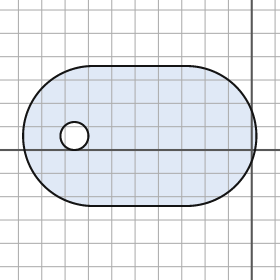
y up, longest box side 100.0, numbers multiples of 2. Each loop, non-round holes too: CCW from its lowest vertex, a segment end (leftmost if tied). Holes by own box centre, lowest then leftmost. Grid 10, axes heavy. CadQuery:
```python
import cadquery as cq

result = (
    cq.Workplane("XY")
    .moveTo(-68.0, -24.0)
    .lineTo(-28.0, -24.0)
    .threePointArc((2.0, 6.0), (-28.0, 36.0))
    .lineTo(-68.0, 36.0)
    .threePointArc((-98.0, 6.0), (-68.0, -24.0))
    .close()
    .moveTo(-76.0, 6.0)
    .circle(6.0)
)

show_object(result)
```